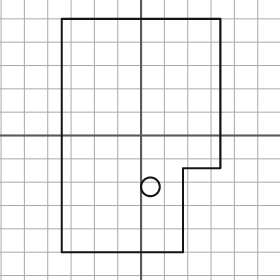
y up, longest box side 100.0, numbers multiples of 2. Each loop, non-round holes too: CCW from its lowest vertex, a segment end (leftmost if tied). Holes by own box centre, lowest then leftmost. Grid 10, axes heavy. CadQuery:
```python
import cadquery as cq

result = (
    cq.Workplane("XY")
    .moveTo(-34.0, -50.0)
    .lineTo(18.0, -50.0)
    .lineTo(18.0, -14.0)
    .lineTo(34.0, -14.0)
    .lineTo(34.0, 50.0)
    .lineTo(-34.0, 50.0)
    .close()
    .moveTo(4.0, -22.0)
    .circle(4.0)
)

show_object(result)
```